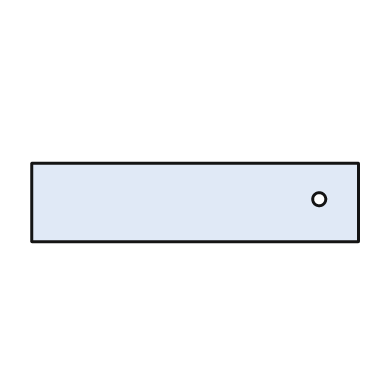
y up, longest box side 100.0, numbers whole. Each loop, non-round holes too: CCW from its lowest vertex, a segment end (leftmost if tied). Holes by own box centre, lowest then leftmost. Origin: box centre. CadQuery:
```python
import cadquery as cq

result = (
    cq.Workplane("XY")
    .moveTo(-50.0, -12.0)
    .lineTo(50.0, -12.0)
    .lineTo(50.0, 12.0)
    .lineTo(-50.0, 12.0)
    .close()
    .moveTo(38.0, 1.0)
    .circle(2.0)
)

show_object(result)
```